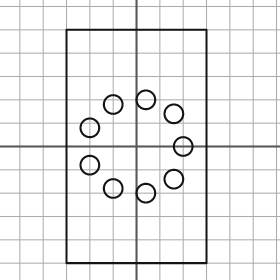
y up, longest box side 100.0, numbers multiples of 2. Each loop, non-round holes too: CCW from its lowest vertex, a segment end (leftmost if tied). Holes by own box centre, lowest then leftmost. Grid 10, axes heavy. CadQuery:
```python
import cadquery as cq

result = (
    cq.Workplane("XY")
    .moveTo(-30.0, -50.0)
    .lineTo(30.0, -50.0)
    .lineTo(30.0, 50.0)
    .lineTo(-30.0, 50.0)
    .close()
    .moveTo(4.0, -20.0)
    .circle(4.0)
    .moveTo(-10.0, -18.0)
    .circle(4.0)
    .moveTo(16.0, -14.0)
    .circle(4.0)
    .moveTo(-20.0, -8.0)
    .circle(4.0)
    .moveTo(20.0, 0.0)
    .circle(4.0)
    .moveTo(-20.0, 8.0)
    .circle(4.0)
    .moveTo(16.0, 14.0)
    .circle(4.0)
    .moveTo(-10.0, 18.0)
    .circle(4.0)
    .moveTo(4.0, 20.0)
    .circle(4.0)
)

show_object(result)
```